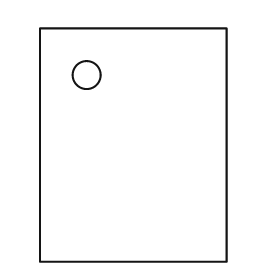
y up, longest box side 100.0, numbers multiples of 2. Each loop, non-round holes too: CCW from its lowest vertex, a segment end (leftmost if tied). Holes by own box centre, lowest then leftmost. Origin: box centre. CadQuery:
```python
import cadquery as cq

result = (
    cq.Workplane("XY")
    .moveTo(-40.0, -50.0)
    .lineTo(40.0, -50.0)
    .lineTo(40.0, 50.0)
    .lineTo(-40.0, 50.0)
    .close()
    .moveTo(-20.0, 30.0)
    .circle(6.0)
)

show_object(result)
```